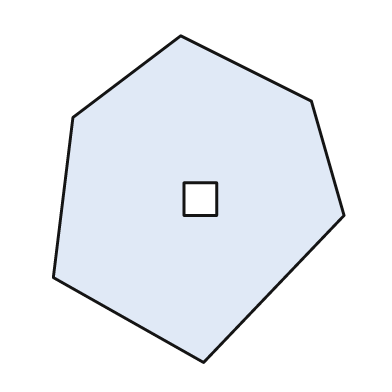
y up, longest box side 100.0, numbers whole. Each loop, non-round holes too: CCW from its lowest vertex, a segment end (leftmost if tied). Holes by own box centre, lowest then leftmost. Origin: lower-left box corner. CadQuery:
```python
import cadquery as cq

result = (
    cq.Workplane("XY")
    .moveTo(46.0, 0.0)
    .lineTo(89.0, 45.0)
    .lineTo(79.0, 80.0)
    .lineTo(39.0, 100.0)
    .lineTo(6.0, 75.0)
    .lineTo(0.0, 26.0)
    .close()
    .moveTo(40.0, 45.0)
    .lineTo(50.0, 45.0)
    .lineTo(50.0, 55.0)
    .lineTo(40.0, 55.0)
    .close()
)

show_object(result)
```